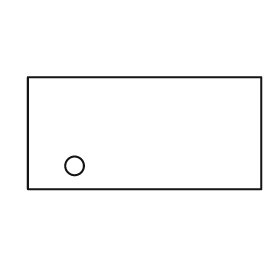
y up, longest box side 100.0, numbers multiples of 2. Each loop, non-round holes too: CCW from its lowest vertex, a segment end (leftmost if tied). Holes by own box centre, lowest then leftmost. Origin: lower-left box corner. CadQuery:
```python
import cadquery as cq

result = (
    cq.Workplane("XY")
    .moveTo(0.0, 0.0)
    .lineTo(100.0, 0.0)
    .lineTo(100.0, 48.0)
    .lineTo(0.0, 48.0)
    .close()
    .moveTo(20.0, 10.0)
    .circle(4.0)
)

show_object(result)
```